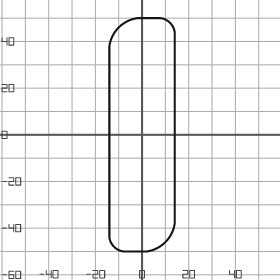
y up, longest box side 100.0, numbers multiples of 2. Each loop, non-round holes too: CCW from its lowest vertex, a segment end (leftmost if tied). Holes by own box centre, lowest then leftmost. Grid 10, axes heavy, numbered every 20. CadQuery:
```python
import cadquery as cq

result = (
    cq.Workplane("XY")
    .moveTo(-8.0, -50.0)
    .lineTo(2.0, -50.0)
    .threePointArc((10.0, -46.0), (14.0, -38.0))
    .lineTo(14.0, 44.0)
    .threePointArc((12.0, 48.0), (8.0, 50.0))
    .lineTo(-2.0, 50.0)
    .threePointArc((-10.0, 46.0), (-14.0, 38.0))
    .lineTo(-14.0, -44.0)
    .threePointArc((-12.0, -48.0), (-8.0, -50.0))
    .close()
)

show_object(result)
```